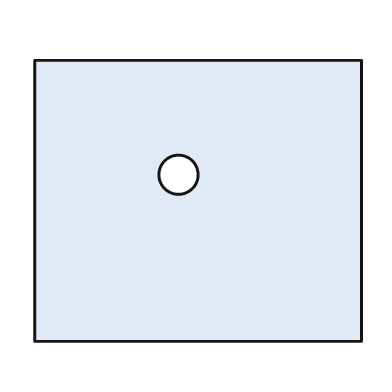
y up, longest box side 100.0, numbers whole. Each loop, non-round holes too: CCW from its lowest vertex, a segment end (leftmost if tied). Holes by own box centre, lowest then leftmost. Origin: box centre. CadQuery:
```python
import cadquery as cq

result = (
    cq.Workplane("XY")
    .moveTo(-50.0, -43.0)
    .lineTo(50.0, -43.0)
    .lineTo(50.0, 43.0)
    .lineTo(-50.0, 43.0)
    .close()
    .moveTo(-6.0, 8.0)
    .circle(6.0)
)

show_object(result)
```